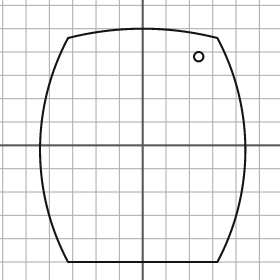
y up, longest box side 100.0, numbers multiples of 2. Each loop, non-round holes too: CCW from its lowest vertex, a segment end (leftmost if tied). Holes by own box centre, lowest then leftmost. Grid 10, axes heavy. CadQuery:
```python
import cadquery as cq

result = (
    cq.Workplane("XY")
    .moveTo(-32.0, -50.0)
    .lineTo(32.0, -50.0)
    .threePointArc((44.0, -2.0), (32.0, 46.0))
    .threePointArc((0.0, 50.0), (-32.0, 46.0))
    .threePointArc((-44.0, -2.0), (-32.0, -50.0))
    .close()
    .moveTo(24.0, 38.0)
    .circle(2.0)
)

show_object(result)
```